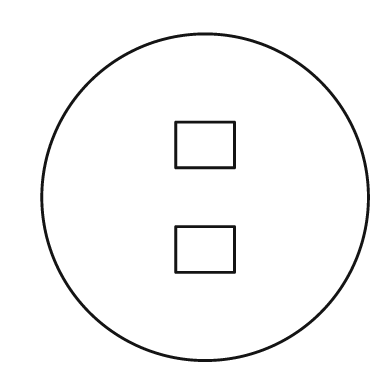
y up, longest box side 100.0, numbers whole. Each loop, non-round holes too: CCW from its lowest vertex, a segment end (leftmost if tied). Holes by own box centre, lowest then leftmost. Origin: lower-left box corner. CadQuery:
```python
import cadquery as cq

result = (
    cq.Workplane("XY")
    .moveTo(50.0, 50.0)
    .circle(50.0)
    .moveTo(41.0, 27.0)
    .lineTo(59.0, 27.0)
    .lineTo(59.0, 41.0)
    .lineTo(41.0, 41.0)
    .close()
    .moveTo(41.0, 59.0)
    .lineTo(59.0, 59.0)
    .lineTo(59.0, 73.0)
    .lineTo(41.0, 73.0)
    .close()
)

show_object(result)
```